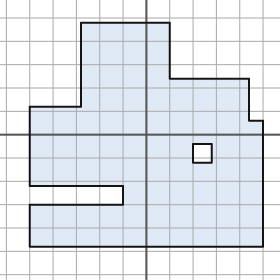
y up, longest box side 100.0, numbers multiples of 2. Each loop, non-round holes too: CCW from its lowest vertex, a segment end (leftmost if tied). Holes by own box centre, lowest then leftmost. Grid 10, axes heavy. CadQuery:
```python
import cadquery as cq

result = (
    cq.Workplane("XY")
    .moveTo(-50.0, -48.0)
    .lineTo(50.0, -48.0)
    .lineTo(50.0, 6.0)
    .lineTo(44.0, 6.0)
    .lineTo(44.0, 24.0)
    .lineTo(10.0, 24.0)
    .lineTo(10.0, 48.0)
    .lineTo(-28.0, 48.0)
    .lineTo(-28.0, 12.0)
    .lineTo(-50.0, 12.0)
    .lineTo(-50.0, -22.0)
    .lineTo(-10.0, -22.0)
    .lineTo(-10.0, -30.0)
    .lineTo(-50.0, -30.0)
    .close()
    .moveTo(20.0, -12.0)
    .lineTo(28.0, -12.0)
    .lineTo(28.0, -4.0)
    .lineTo(20.0, -4.0)
    .close()
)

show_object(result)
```